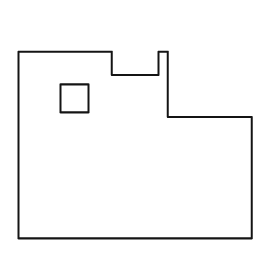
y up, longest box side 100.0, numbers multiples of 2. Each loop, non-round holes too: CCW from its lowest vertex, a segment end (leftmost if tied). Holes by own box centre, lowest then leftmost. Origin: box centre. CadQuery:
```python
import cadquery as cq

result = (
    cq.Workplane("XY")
    .moveTo(-50.0, -40.0)
    .lineTo(50.0, -40.0)
    .lineTo(50.0, 12.0)
    .lineTo(14.0, 12.0)
    .lineTo(14.0, 40.0)
    .lineTo(10.0, 40.0)
    .lineTo(10.0, 30.0)
    .lineTo(-10.0, 30.0)
    .lineTo(-10.0, 40.0)
    .lineTo(-50.0, 40.0)
    .close()
    .moveTo(-32.0, 14.0)
    .lineTo(-20.0, 14.0)
    .lineTo(-20.0, 26.0)
    .lineTo(-32.0, 26.0)
    .close()
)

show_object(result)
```